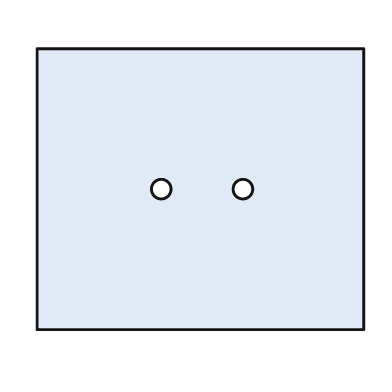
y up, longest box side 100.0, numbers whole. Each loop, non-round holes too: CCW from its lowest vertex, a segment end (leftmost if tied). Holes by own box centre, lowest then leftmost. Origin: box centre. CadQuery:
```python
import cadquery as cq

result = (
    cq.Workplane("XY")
    .moveTo(-50.0, -43.0)
    .lineTo(50.0, -43.0)
    .lineTo(50.0, 43.0)
    .lineTo(-50.0, 43.0)
    .close()
    .moveTo(-12.0, 0.0)
    .circle(3.0)
    .moveTo(13.0, 0.0)
    .circle(3.0)
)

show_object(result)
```